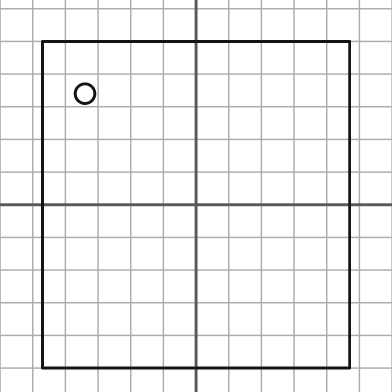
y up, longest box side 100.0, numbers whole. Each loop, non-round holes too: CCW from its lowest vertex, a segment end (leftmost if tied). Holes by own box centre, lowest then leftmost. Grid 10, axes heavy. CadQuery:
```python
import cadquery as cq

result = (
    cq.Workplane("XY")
    .moveTo(-47.0, -50.0)
    .lineTo(47.0, -50.0)
    .lineTo(47.0, 50.0)
    .lineTo(-47.0, 50.0)
    .close()
    .moveTo(-34.0, 34.0)
    .circle(3.0)
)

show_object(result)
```